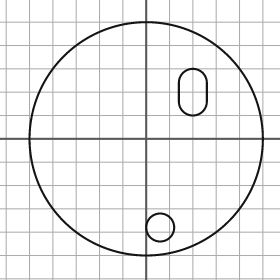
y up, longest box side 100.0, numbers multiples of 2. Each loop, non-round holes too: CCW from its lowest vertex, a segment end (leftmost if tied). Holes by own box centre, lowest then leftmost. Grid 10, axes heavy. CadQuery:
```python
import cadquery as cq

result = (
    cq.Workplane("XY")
    .moveTo(0.0, 0.0)
    .circle(50.0)
    .moveTo(6.0, -38.0)
    .circle(6.0)
    .moveTo(14.0, 16.0)
    .threePointArc((20.0, 10.0), (26.0, 16.0))
    .lineTo(26.0, 24.0)
    .threePointArc((20.0, 30.0), (14.0, 24.0))
    .close()
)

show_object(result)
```